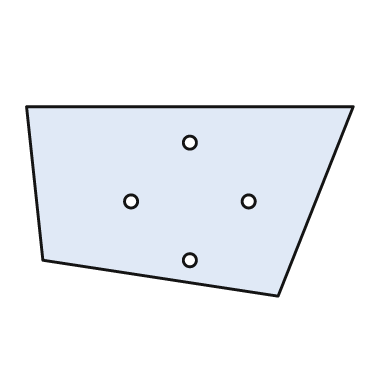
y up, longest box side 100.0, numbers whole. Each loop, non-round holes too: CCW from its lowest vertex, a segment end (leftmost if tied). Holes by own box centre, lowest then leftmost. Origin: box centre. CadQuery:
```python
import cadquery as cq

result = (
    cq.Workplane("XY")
    .moveTo(27.0, -29.0)
    .lineTo(50.0, 29.0)
    .lineTo(-50.0, 29.0)
    .lineTo(-45.0, -18.0)
    .close()
    .moveTo(0.0, -18.0)
    .circle(2.0)
    .moveTo(-18.0, 0.0)
    .circle(2.0)
    .moveTo(18.0, 0.0)
    .circle(2.0)
    .moveTo(0.0, 18.0)
    .circle(2.0)
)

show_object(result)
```